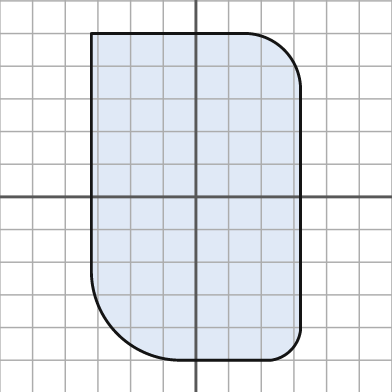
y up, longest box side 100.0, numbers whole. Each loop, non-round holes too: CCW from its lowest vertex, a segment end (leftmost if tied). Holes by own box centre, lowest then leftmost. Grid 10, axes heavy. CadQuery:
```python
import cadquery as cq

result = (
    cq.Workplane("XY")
    .moveTo(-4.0, -50.0)
    .lineTo(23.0, -50.0)
    .threePointArc((29.0, -47.0), (32.0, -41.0))
    .lineTo(32.0, 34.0)
    .threePointArc((27.0, 45.0), (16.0, 50.0))
    .lineTo(-32.0, 50.0)
    .lineTo(-32.0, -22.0)
    .threePointArc((-24.0, -42.0), (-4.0, -50.0))
    .close()
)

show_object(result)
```